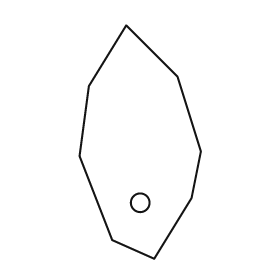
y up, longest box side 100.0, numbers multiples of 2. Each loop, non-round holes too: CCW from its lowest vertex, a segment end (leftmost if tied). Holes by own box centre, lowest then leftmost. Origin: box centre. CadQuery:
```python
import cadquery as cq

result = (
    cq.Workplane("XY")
    .moveTo(6.0, -50.0)
    .lineTo(22.0, -24.0)
    .lineTo(26.0, -4.0)
    .lineTo(16.0, 28.0)
    .lineTo(-6.0, 50.0)
    .lineTo(-22.0, 24.0)
    .lineTo(-26.0, -6.0)
    .lineTo(-12.0, -42.0)
    .close()
    .moveTo(0.0, -26.0)
    .circle(4.0)
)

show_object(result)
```